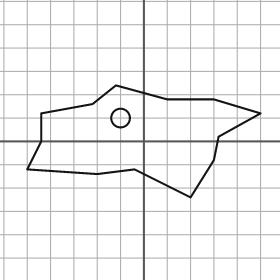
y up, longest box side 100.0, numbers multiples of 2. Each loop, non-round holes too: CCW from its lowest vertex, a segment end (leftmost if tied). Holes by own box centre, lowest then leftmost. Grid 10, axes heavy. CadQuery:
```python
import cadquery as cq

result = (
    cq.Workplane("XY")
    .moveTo(20.0, -24.0)
    .lineTo(30.0, -8.0)
    .lineTo(32.0, 2.0)
    .lineTo(50.0, 12.0)
    .lineTo(30.0, 18.0)
    .lineTo(10.0, 18.0)
    .lineTo(-12.0, 24.0)
    .lineTo(-22.0, 16.0)
    .lineTo(-44.0, 12.0)
    .lineTo(-44.0, 0.0)
    .lineTo(-50.0, -12.0)
    .lineTo(-20.0, -14.0)
    .lineTo(-4.0, -12.0)
    .close()
    .moveTo(-10.0, 10.0)
    .circle(4.0)
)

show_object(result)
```